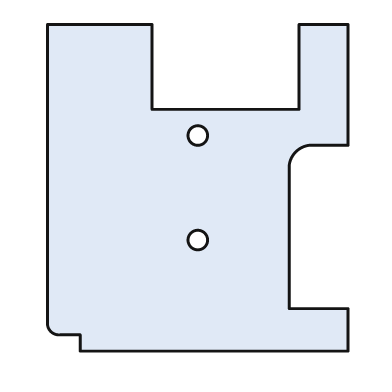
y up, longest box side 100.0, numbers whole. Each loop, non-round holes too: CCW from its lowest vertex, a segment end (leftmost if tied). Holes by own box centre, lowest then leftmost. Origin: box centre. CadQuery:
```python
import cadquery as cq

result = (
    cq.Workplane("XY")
    .moveTo(-36.0, -50.0)
    .lineTo(46.0, -50.0)
    .lineTo(46.0, -37.0)
    .lineTo(28.0, -37.0)
    .lineTo(28.0, 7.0)
    .threePointArc((30.0, 11.0), (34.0, 13.0))
    .lineTo(46.0, 13.0)
    .lineTo(46.0, 50.0)
    .lineTo(31.0, 50.0)
    .lineTo(31.0, 24.0)
    .lineTo(-14.0, 24.0)
    .lineTo(-14.0, 50.0)
    .lineTo(-46.0, 50.0)
    .lineTo(-46.0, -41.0)
    .threePointArc((-45.0, -44.0), (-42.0, -45.0))
    .lineTo(-36.0, -45.0)
    .close()
    .moveTo(0.0, -16.0)
    .circle(3.0)
    .moveTo(0.0, 16.0)
    .circle(3.0)
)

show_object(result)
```